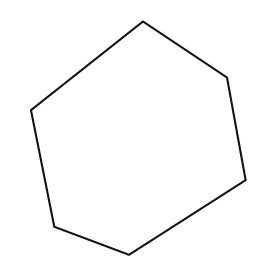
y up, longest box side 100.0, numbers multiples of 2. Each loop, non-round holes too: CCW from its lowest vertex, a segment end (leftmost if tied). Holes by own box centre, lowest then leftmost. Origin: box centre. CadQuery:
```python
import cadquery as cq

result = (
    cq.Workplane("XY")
    .moveTo(-4.0, -50.0)
    .lineTo(46.0, -18.0)
    .lineTo(38.0, 26.0)
    .lineTo(2.0, 50.0)
    .lineTo(-46.0, 12.0)
    .lineTo(-36.0, -38.0)
    .close()
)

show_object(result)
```